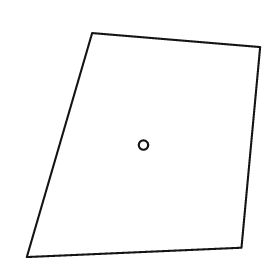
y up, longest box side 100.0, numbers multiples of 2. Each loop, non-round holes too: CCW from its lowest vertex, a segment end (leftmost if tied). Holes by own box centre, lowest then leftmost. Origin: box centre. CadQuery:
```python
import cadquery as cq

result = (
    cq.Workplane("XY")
    .moveTo(-50.0, -48.0)
    .lineTo(42.0, -44.0)
    .lineTo(50.0, 42.0)
    .lineTo(-22.0, 48.0)
    .close()
    .moveTo(0.0, 0.0)
    .circle(2.0)
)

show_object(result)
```